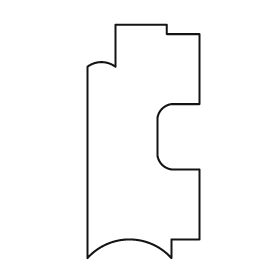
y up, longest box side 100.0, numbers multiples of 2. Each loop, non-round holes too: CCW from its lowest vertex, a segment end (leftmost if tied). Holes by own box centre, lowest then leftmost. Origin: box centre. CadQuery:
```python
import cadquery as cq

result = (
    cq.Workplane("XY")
    .moveTo(-24.0, -50.0)
    .threePointArc((-6.0, -42.0), (12.0, -50.0))
    .lineTo(12.0, -42.0)
    .lineTo(24.0, -42.0)
    .lineTo(24.0, -12.0)
    .lineTo(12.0, -12.0)
    .threePointArc((8.0, -10.0), (6.0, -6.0))
    .lineTo(6.0, 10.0)
    .threePointArc((8.0, 14.0), (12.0, 16.0))
    .lineTo(24.0, 16.0)
    .lineTo(24.0, 46.0)
    .lineTo(10.0, 46.0)
    .lineTo(10.0, 50.0)
    .lineTo(-12.0, 50.0)
    .lineTo(-12.0, 32.0)
    .threePointArc((-18.0, 34.0), (-24.0, 32.0))
    .close()
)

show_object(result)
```